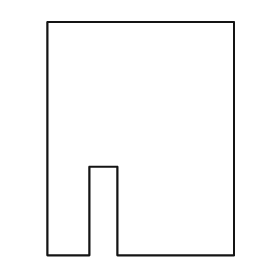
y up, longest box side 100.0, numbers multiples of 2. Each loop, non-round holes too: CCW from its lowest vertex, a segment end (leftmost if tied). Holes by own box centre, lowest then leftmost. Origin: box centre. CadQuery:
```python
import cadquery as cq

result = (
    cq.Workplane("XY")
    .moveTo(-40.0, -50.0)
    .lineTo(-22.0, -50.0)
    .lineTo(-22.0, -12.0)
    .lineTo(-10.0, -12.0)
    .lineTo(-10.0, -50.0)
    .lineTo(40.0, -50.0)
    .lineTo(40.0, 50.0)
    .lineTo(-40.0, 50.0)
    .close()
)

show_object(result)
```